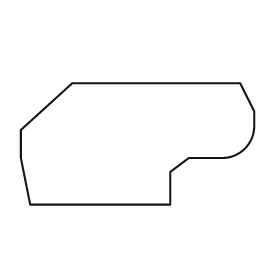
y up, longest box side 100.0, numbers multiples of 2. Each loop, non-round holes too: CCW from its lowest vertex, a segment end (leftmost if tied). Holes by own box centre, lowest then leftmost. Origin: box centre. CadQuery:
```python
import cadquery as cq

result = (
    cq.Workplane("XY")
    .moveTo(-46.0, -26.0)
    .lineTo(14.0, -26.0)
    .lineTo(14.0, -12.0)
    .lineTo(22.0, -6.0)
    .lineTo(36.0, -6.0)
    .threePointArc((46.0, -2.0), (50.0, 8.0))
    .lineTo(50.0, 14.0)
    .lineTo(44.0, 26.0)
    .lineTo(-28.0, 26.0)
    .lineTo(-50.0, 6.0)
    .lineTo(-50.0, -6.0)
    .close()
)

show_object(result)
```